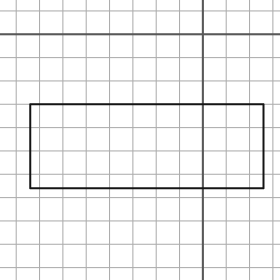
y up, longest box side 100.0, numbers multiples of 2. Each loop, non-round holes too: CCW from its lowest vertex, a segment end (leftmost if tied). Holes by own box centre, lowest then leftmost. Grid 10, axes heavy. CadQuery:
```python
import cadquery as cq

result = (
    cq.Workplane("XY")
    .moveTo(-74.0, -66.0)
    .lineTo(26.0, -66.0)
    .lineTo(26.0, -30.0)
    .lineTo(-74.0, -30.0)
    .close()
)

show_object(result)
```